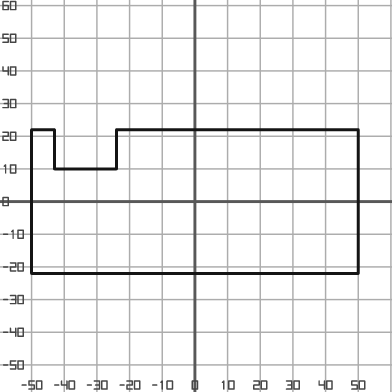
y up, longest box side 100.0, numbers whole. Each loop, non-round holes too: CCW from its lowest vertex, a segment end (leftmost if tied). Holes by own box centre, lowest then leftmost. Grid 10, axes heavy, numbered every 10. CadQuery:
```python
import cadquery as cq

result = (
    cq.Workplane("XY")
    .moveTo(-50.0, -22.0)
    .lineTo(50.0, -22.0)
    .lineTo(50.0, 22.0)
    .lineTo(-24.0, 22.0)
    .lineTo(-24.0, 10.0)
    .lineTo(-43.0, 10.0)
    .lineTo(-43.0, 22.0)
    .lineTo(-50.0, 22.0)
    .close()
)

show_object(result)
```